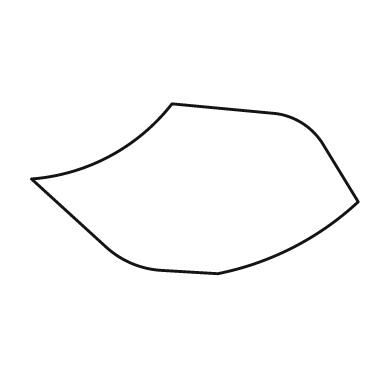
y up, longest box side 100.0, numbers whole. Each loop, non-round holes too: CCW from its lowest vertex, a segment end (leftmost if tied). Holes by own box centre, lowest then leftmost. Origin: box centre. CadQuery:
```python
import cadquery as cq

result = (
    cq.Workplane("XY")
    .moveTo(7.0, -26.0)
    .threePointArc((30.0, -18.0), (50.0, -4.0))
    .lineTo(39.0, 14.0)
    .threePointArc((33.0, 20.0), (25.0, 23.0))
    .lineTo(-7.0, 26.0)
    .threePointArc((-26.0, 10.0), (-50.0, 3.0))
    .lineTo(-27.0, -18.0)
    .threePointArc((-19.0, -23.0), (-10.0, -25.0))
    .close()
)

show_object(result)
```